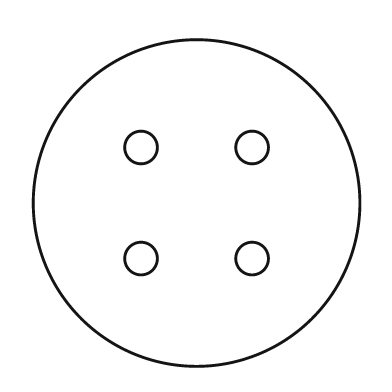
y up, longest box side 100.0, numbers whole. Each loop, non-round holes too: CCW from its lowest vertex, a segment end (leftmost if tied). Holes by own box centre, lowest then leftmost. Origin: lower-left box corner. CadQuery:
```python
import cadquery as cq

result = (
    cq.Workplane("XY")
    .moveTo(50.0, 50.0)
    .circle(50.0)
    .moveTo(33.0, 33.0)
    .circle(5.0)
    .moveTo(67.0, 33.0)
    .circle(5.0)
    .moveTo(33.0, 67.0)
    .circle(5.0)
    .moveTo(67.0, 67.0)
    .circle(5.0)
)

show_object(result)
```